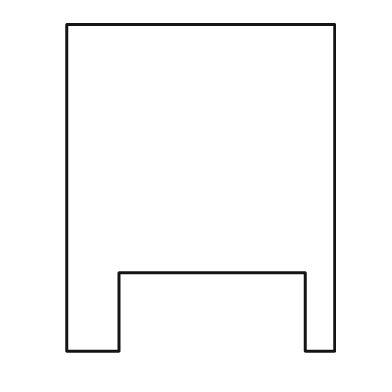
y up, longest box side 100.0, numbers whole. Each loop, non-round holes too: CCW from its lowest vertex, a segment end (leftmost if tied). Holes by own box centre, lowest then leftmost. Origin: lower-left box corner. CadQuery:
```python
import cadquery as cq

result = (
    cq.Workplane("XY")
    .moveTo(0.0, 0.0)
    .lineTo(16.0, 0.0)
    .lineTo(16.0, 24.0)
    .lineTo(73.0, 24.0)
    .lineTo(73.0, 0.0)
    .lineTo(82.0, 0.0)
    .lineTo(82.0, 100.0)
    .lineTo(0.0, 100.0)
    .close()
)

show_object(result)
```